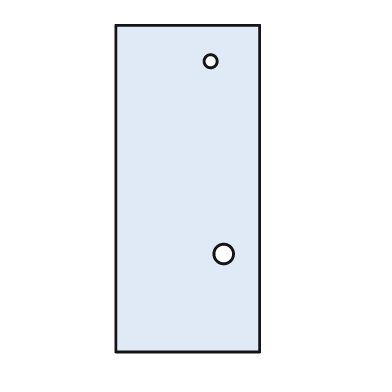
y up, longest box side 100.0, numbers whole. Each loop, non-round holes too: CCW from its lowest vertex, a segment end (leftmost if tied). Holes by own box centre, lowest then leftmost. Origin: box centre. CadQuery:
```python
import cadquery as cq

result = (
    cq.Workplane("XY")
    .moveTo(-22.0, -50.0)
    .lineTo(22.0, -50.0)
    .lineTo(22.0, 50.0)
    .lineTo(-22.0, 50.0)
    .close()
    .moveTo(11.0, -20.0)
    .circle(3.0)
    .moveTo(7.0, 39.0)
    .circle(2.0)
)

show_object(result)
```